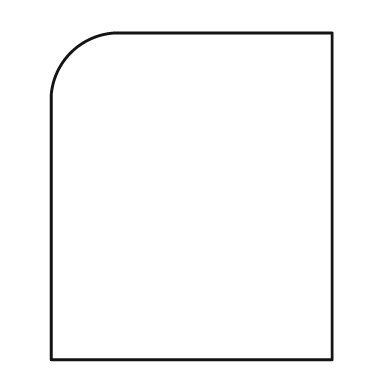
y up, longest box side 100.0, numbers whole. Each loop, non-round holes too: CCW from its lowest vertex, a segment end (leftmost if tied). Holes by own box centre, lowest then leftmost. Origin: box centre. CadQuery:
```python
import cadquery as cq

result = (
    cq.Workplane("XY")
    .moveTo(-43.0, -50.0)
    .lineTo(43.0, -50.0)
    .lineTo(43.0, 50.0)
    .lineTo(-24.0, 50.0)
    .threePointArc((-37.0, 44.0), (-43.0, 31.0))
    .close()
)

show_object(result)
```